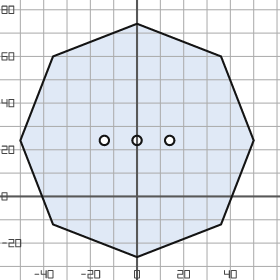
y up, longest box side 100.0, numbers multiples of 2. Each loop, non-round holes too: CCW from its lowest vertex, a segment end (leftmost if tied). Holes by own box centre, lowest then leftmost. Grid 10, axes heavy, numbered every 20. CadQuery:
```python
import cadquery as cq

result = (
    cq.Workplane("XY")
    .moveTo(0.0, -26.0)
    .lineTo(36.0, -12.0)
    .lineTo(50.0, 24.0)
    .lineTo(36.0, 60.0)
    .lineTo(0.0, 74.0)
    .lineTo(-36.0, 60.0)
    .lineTo(-50.0, 24.0)
    .lineTo(-36.0, -12.0)
    .close()
    .moveTo(-14.0, 24.0)
    .circle(2.0)
    .moveTo(0.0, 24.0)
    .circle(2.0)
    .moveTo(14.0, 24.0)
    .circle(2.0)
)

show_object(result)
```